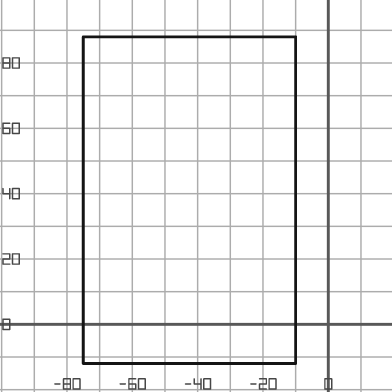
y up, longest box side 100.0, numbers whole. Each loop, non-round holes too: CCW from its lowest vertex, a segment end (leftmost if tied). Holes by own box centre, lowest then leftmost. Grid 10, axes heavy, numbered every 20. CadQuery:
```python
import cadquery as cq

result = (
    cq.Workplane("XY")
    .moveTo(-75.0, -12.0)
    .lineTo(-10.0, -12.0)
    .lineTo(-10.0, 88.0)
    .lineTo(-75.0, 88.0)
    .close()
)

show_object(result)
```